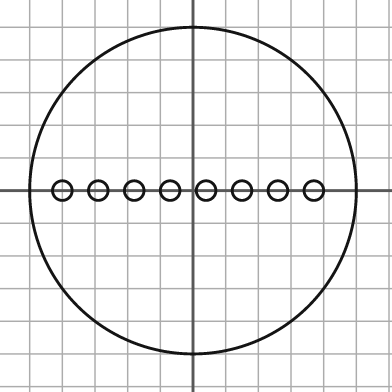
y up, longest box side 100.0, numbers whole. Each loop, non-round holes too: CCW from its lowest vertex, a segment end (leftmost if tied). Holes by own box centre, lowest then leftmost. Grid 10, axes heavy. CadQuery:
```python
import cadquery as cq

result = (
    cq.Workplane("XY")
    .moveTo(0.0, 0.0)
    .circle(50.0)
    .moveTo(-40.0, 0.0)
    .circle(3.0)
    .moveTo(-29.0, 0.0)
    .circle(3.0)
    .moveTo(-18.0, 0.0)
    .circle(3.0)
    .moveTo(-7.0, 0.0)
    .circle(3.0)
    .moveTo(4.0, 0.0)
    .circle(3.0)
    .moveTo(15.0, 0.0)
    .circle(3.0)
    .moveTo(26.0, 0.0)
    .circle(3.0)
    .moveTo(37.0, 0.0)
    .circle(3.0)
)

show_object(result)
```